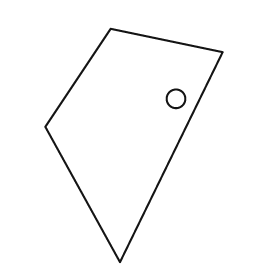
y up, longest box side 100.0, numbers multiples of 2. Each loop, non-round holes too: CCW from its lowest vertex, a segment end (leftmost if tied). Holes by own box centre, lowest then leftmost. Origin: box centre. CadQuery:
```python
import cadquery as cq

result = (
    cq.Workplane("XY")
    .moveTo(-6.0, -50.0)
    .lineTo(38.0, 40.0)
    .lineTo(-10.0, 50.0)
    .lineTo(-38.0, 8.0)
    .close()
    .moveTo(18.0, 20.0)
    .circle(4.0)
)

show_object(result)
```